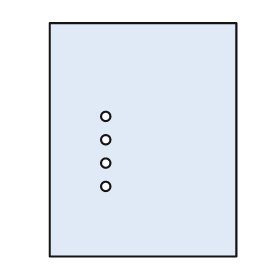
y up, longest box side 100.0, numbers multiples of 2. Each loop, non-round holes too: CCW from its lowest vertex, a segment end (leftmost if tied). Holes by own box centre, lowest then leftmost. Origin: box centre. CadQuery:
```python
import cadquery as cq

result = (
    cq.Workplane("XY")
    .moveTo(-40.0, -50.0)
    .lineTo(40.0, -50.0)
    .lineTo(40.0, 50.0)
    .lineTo(-40.0, 50.0)
    .close()
    .moveTo(-16.0, -20.0)
    .circle(2.0)
    .moveTo(-16.0, -10.0)
    .circle(2.0)
    .moveTo(-16.0, 0.0)
    .circle(2.0)
    .moveTo(-16.0, 10.0)
    .circle(2.0)
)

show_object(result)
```